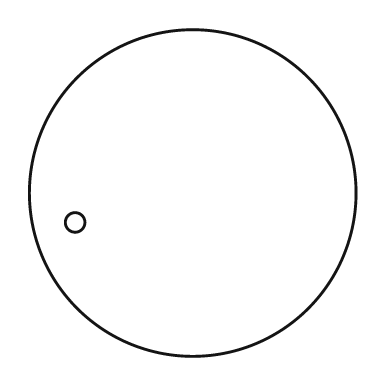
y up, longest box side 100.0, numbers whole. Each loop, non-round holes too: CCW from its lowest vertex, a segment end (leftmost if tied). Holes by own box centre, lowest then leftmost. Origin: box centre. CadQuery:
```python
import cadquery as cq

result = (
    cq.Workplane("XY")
    .moveTo(0.0, 0.0)
    .circle(50.0)
    .moveTo(-36.0, -9.0)
    .circle(3.0)
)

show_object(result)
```